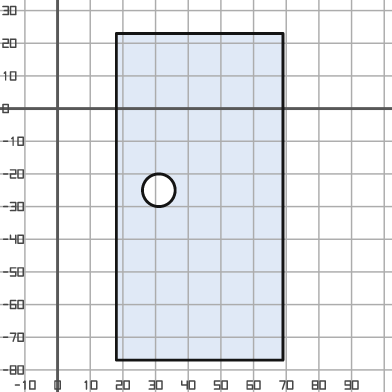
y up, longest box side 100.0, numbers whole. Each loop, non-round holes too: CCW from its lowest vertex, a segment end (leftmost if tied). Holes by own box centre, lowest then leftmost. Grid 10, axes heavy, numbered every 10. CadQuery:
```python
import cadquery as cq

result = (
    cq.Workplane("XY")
    .moveTo(18.0, -77.0)
    .lineTo(69.0, -77.0)
    .lineTo(69.0, 23.0)
    .lineTo(18.0, 23.0)
    .close()
    .moveTo(31.0, -25.0)
    .circle(5.0)
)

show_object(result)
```